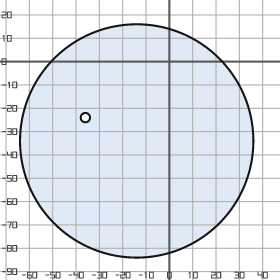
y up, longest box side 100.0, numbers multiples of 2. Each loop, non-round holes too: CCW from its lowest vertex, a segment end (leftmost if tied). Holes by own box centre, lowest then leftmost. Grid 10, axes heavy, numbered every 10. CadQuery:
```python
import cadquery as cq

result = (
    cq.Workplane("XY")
    .moveTo(-14.0, -34.0)
    .circle(50.0)
    .moveTo(-36.0, -24.0)
    .circle(2.0)
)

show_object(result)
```